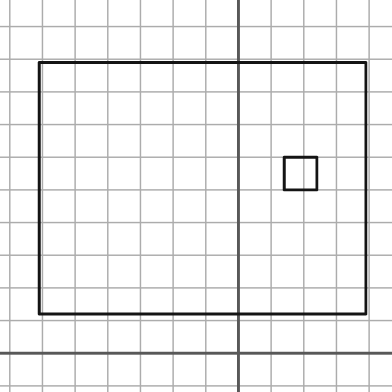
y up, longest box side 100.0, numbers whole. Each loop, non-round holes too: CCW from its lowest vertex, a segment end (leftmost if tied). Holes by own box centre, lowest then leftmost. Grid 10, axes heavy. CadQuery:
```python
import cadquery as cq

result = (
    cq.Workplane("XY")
    .moveTo(-61.0, 12.0)
    .lineTo(39.0, 12.0)
    .lineTo(39.0, 89.0)
    .lineTo(-61.0, 89.0)
    .close()
    .moveTo(14.0, 50.0)
    .lineTo(24.0, 50.0)
    .lineTo(24.0, 60.0)
    .lineTo(14.0, 60.0)
    .close()
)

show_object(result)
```